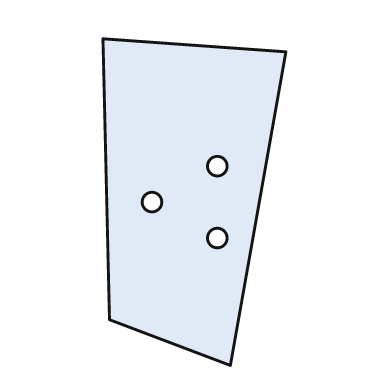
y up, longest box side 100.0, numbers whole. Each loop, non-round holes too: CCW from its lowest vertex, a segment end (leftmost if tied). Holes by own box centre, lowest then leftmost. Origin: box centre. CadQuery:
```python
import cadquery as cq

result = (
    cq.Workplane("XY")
    .moveTo(11.0, -50.0)
    .lineTo(28.0, 46.0)
    .lineTo(-28.0, 50.0)
    .lineTo(-26.0, -36.0)
    .close()
    .moveTo(7.0, -11.0)
    .circle(3.0)
    .moveTo(-13.0, 0.0)
    .circle(3.0)
    .moveTo(7.0, 11.0)
    .circle(3.0)
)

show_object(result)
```